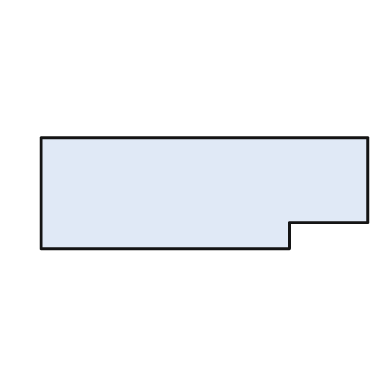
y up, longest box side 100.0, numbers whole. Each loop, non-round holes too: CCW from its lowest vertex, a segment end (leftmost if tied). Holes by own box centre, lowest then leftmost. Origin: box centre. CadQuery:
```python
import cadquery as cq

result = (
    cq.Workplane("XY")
    .moveTo(-50.0, -17.0)
    .lineTo(26.0, -17.0)
    .lineTo(26.0, -9.0)
    .lineTo(50.0, -9.0)
    .lineTo(50.0, 17.0)
    .lineTo(-50.0, 17.0)
    .close()
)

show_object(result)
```